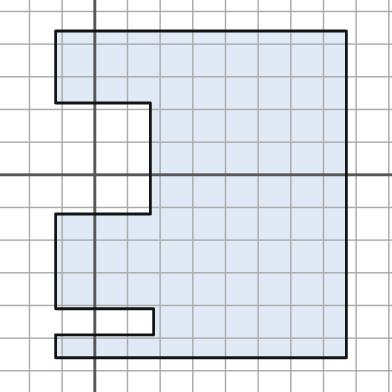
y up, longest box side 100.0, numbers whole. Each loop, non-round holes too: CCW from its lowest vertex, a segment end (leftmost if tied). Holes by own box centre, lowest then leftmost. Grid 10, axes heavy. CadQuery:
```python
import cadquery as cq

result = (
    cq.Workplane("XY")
    .moveTo(-12.0, -56.0)
    .lineTo(77.0, -56.0)
    .lineTo(77.0, 44.0)
    .lineTo(-12.0, 44.0)
    .lineTo(-12.0, 22.0)
    .lineTo(17.0, 22.0)
    .lineTo(17.0, -12.0)
    .lineTo(-12.0, -12.0)
    .lineTo(-12.0, -41.0)
    .lineTo(18.0, -41.0)
    .lineTo(18.0, -49.0)
    .lineTo(-12.0, -49.0)
    .close()
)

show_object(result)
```